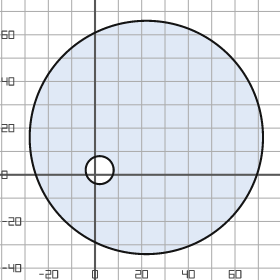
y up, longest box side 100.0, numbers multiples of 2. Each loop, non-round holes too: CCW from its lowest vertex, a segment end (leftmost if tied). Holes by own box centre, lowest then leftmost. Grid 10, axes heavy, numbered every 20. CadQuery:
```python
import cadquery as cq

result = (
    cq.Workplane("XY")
    .moveTo(22.0, 16.0)
    .circle(50.0)
    .moveTo(2.0, 2.0)
    .circle(6.0)
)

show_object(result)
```